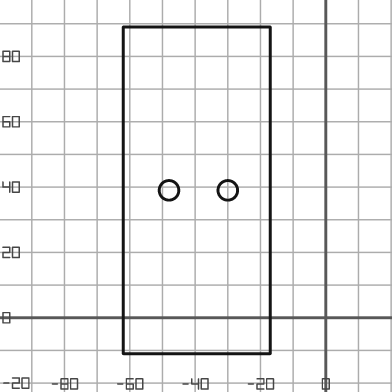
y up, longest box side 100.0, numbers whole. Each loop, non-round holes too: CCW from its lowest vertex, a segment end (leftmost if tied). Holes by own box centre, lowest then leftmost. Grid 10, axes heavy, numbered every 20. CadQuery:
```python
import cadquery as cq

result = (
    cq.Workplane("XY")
    .moveTo(-62.0, -11.0)
    .lineTo(-17.0, -11.0)
    .lineTo(-17.0, 89.0)
    .lineTo(-62.0, 89.0)
    .close()
    .moveTo(-48.0, 39.0)
    .circle(3.0)
    .moveTo(-30.0, 39.0)
    .circle(3.0)
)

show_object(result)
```